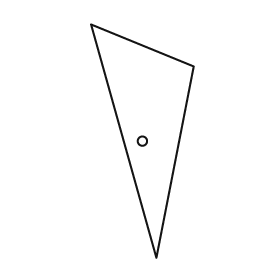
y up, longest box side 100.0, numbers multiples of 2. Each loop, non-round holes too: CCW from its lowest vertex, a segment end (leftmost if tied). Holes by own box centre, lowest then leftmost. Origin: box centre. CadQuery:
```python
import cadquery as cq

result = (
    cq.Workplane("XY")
    .moveTo(6.0, -50.0)
    .lineTo(22.0, 32.0)
    .lineTo(-22.0, 50.0)
    .close()
    .moveTo(0.0, 0.0)
    .circle(2.0)
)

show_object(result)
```